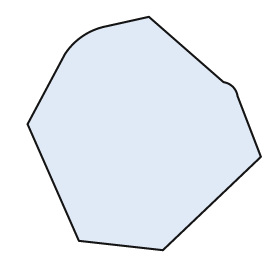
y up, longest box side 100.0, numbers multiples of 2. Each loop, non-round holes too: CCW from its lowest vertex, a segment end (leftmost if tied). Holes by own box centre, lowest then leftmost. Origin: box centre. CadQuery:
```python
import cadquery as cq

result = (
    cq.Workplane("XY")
    .moveTo(8.0, -50.0)
    .lineTo(50.0, -10.0)
    .lineTo(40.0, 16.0)
    .threePointArc((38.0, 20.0), (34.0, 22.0))
    .lineTo(2.0, 50.0)
    .lineTo(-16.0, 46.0)
    .threePointArc((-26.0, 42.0), (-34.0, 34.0))
    .lineTo(-50.0, 4.0)
    .lineTo(-28.0, -46.0)
    .close()
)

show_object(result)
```